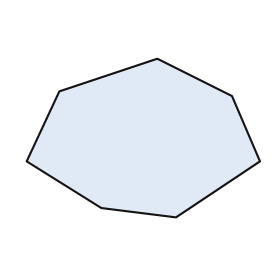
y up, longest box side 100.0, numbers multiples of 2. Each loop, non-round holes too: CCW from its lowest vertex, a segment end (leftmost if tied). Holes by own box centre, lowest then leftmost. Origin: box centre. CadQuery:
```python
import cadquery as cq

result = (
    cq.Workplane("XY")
    .moveTo(14.0, -34.0)
    .lineTo(50.0, -10.0)
    .lineTo(38.0, 18.0)
    .lineTo(6.0, 34.0)
    .lineTo(-36.0, 20.0)
    .lineTo(-50.0, -10.0)
    .lineTo(-18.0, -30.0)
    .close()
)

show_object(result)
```